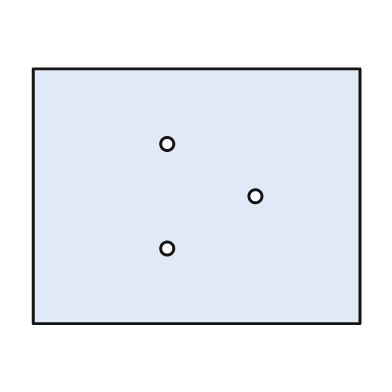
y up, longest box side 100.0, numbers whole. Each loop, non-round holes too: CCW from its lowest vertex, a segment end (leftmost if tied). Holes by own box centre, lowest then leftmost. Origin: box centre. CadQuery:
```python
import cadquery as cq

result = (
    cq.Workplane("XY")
    .moveTo(-50.0, -39.0)
    .lineTo(50.0, -39.0)
    .lineTo(50.0, 39.0)
    .lineTo(-50.0, 39.0)
    .close()
    .moveTo(-9.0, -16.0)
    .circle(2.0)
    .moveTo(18.0, 0.0)
    .circle(2.0)
    .moveTo(-9.0, 16.0)
    .circle(2.0)
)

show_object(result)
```